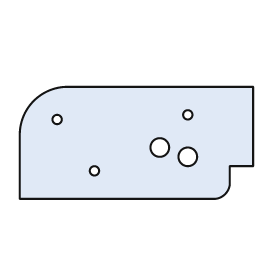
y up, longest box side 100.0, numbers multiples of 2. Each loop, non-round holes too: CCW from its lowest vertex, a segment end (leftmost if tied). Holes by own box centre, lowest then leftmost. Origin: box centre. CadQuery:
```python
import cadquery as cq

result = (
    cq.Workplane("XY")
    .moveTo(-50.0, -24.0)
    .lineTo(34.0, -24.0)
    .threePointArc((38.0, -22.0), (40.0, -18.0))
    .lineTo(40.0, -10.0)
    .lineTo(50.0, -10.0)
    .lineTo(50.0, 24.0)
    .lineTo(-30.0, 24.0)
    .threePointArc((-44.0, 18.0), (-50.0, 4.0))
    .close()
    .moveTo(-18.0, -12.0)
    .circle(2.0)
    .moveTo(22.0, -6.0)
    .circle(4.0)
    .moveTo(10.0, -2.0)
    .circle(4.0)
    .moveTo(-34.0, 10.0)
    .circle(2.0)
    .moveTo(22.0, 12.0)
    .circle(2.0)
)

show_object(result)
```